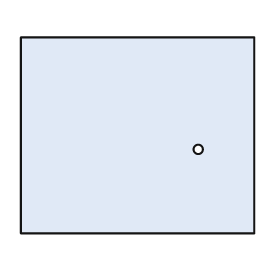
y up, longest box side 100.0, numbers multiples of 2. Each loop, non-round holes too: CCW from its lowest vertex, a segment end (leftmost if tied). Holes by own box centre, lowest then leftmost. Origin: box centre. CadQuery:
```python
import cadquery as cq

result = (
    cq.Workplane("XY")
    .moveTo(-50.0, -42.0)
    .lineTo(50.0, -42.0)
    .lineTo(50.0, 42.0)
    .lineTo(-50.0, 42.0)
    .close()
    .moveTo(26.0, -6.0)
    .circle(2.0)
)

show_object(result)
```